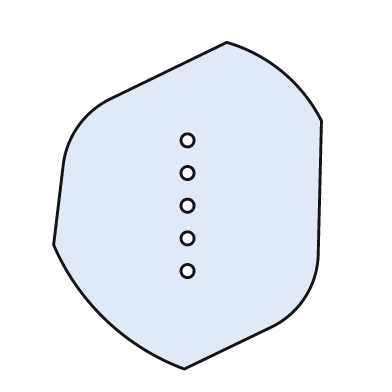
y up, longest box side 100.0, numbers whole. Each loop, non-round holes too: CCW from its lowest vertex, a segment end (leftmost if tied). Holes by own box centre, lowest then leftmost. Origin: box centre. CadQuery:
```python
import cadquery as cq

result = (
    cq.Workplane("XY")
    .moveTo(-1.0, -50.0)
    .lineTo(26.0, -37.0)
    .threePointArc((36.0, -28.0), (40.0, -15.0))
    .lineTo(41.0, 26.0)
    .threePointArc((29.0, 41.0), (12.0, 50.0))
    .lineTo(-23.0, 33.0)
    .threePointArc((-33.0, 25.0), (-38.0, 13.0))
    .lineTo(-41.0, -12.0)
    .threePointArc((-25.0, -35.0), (-1.0, -50.0))
    .close()
    .moveTo(0.0, -20.0)
    .circle(2.0)
    .moveTo(0.0, -10.0)
    .circle(2.0)
    .moveTo(0.0, 0.0)
    .circle(2.0)
    .moveTo(0.0, 10.0)
    .circle(2.0)
    .moveTo(0.0, 20.0)
    .circle(2.0)
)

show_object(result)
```